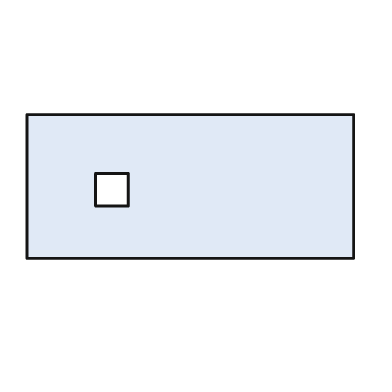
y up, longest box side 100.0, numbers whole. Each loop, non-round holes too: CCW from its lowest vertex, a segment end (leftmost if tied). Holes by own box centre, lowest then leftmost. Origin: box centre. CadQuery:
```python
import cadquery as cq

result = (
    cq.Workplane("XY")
    .moveTo(-50.0, -22.0)
    .lineTo(50.0, -22.0)
    .lineTo(50.0, 22.0)
    .lineTo(-50.0, 22.0)
    .close()
    .moveTo(-29.0, -6.0)
    .lineTo(-19.0, -6.0)
    .lineTo(-19.0, 4.0)
    .lineTo(-29.0, 4.0)
    .close()
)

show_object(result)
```